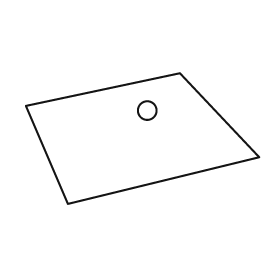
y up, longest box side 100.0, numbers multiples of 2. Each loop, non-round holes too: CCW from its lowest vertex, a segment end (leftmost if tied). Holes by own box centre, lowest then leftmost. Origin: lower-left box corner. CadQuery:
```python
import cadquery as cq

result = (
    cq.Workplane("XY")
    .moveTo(18.0, 0.0)
    .lineTo(100.0, 20.0)
    .lineTo(66.0, 56.0)
    .lineTo(0.0, 42.0)
    .close()
    .moveTo(52.0, 40.0)
    .circle(4.0)
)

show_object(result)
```